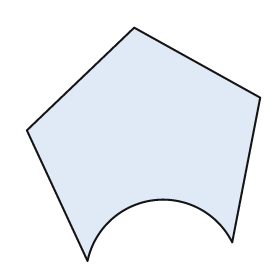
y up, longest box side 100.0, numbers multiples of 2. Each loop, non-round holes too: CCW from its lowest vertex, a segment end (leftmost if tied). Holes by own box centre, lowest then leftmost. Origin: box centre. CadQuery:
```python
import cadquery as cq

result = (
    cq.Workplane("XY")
    .moveTo(-24.0, -50.0)
    .threePointArc((4.0, -24.0), (38.0, -42.0))
    .lineTo(50.0, 20.0)
    .lineTo(-4.0, 50.0)
    .lineTo(-50.0, 6.0)
    .close()
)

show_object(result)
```